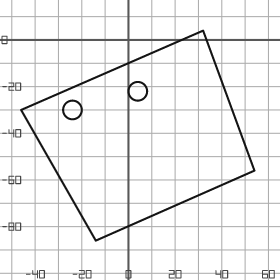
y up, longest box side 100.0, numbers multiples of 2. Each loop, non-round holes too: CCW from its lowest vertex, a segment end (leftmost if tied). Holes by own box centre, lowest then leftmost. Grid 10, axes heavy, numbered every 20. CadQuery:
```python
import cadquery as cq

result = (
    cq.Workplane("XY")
    .moveTo(-14.0, -86.0)
    .lineTo(54.0, -56.0)
    .lineTo(32.0, 4.0)
    .lineTo(-46.0, -30.0)
    .close()
    .moveTo(-24.0, -30.0)
    .circle(4.0)
    .moveTo(4.0, -22.0)
    .circle(4.0)
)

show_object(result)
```